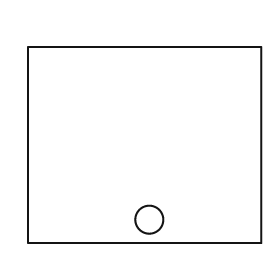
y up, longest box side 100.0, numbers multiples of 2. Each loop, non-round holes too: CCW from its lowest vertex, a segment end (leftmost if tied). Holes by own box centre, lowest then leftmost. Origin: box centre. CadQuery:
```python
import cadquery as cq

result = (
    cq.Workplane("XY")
    .moveTo(-50.0, -42.0)
    .lineTo(50.0, -42.0)
    .lineTo(50.0, 42.0)
    .lineTo(-50.0, 42.0)
    .close()
    .moveTo(2.0, -32.0)
    .circle(6.0)
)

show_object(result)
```